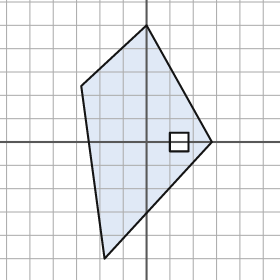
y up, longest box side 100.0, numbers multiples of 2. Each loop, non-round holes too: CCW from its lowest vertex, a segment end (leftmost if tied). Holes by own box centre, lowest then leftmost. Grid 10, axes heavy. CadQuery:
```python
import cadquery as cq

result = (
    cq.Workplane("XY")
    .moveTo(-18.0, -50.0)
    .lineTo(28.0, 0.0)
    .lineTo(0.0, 50.0)
    .lineTo(-28.0, 24.0)
    .close()
    .moveTo(10.0, -4.0)
    .lineTo(18.0, -4.0)
    .lineTo(18.0, 4.0)
    .lineTo(10.0, 4.0)
    .close()
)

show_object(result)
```